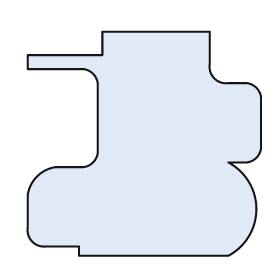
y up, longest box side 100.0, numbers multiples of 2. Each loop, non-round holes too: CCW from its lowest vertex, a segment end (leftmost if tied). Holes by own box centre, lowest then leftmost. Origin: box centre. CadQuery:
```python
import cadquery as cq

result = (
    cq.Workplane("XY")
    .moveTo(-28.0, -48.0)
    .lineTo(36.0, -48.0)
    .threePointArc((48.0, -28.0), (36.0, -8.0))
    .lineTo(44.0, -8.0)
    .threePointArc((48.0, -6.0), (50.0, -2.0))
    .lineTo(50.0, 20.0)
    .threePointArc((48.0, 24.0), (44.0, 26.0))
    .lineTo(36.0, 26.0)
    .threePointArc((30.0, 28.0), (28.0, 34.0))
    .lineTo(28.0, 48.0)
    .lineTo(-18.0, 48.0)
    .lineTo(-18.0, 38.0)
    .lineTo(-50.0, 38.0)
    .lineTo(-50.0, 32.0)
    .lineTo(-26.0, 32.0)
    .threePointArc((-22.0, 30.0), (-20.0, 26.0))
    .lineTo(-20.0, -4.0)
    .threePointArc((-22.0, -8.0), (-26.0, -10.0))
    .lineTo(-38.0, -10.0)
    .threePointArc((-46.0, -14.0), (-50.0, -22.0))
    .lineTo(-50.0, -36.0)
    .threePointArc((-48.0, -42.0), (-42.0, -44.0))
    .lineTo(-28.0, -44.0)
    .close()
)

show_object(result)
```